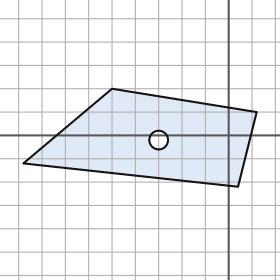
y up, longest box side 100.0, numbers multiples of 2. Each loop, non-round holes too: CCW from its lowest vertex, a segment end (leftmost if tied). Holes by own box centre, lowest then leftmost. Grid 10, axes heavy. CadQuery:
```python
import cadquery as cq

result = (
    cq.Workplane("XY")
    .moveTo(4.0, -22.0)
    .lineTo(12.0, 10.0)
    .lineTo(-50.0, 20.0)
    .lineTo(-88.0, -12.0)
    .close()
    .moveTo(-30.0, -2.0)
    .circle(4.0)
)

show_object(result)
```